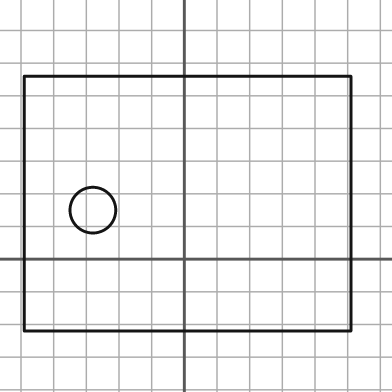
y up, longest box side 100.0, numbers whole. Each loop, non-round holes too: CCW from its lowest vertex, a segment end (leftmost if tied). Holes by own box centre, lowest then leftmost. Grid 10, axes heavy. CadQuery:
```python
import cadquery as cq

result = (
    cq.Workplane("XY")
    .moveTo(-49.0, -22.0)
    .lineTo(51.0, -22.0)
    .lineTo(51.0, 56.0)
    .lineTo(-49.0, 56.0)
    .close()
    .moveTo(-28.0, 15.0)
    .circle(7.0)
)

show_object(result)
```